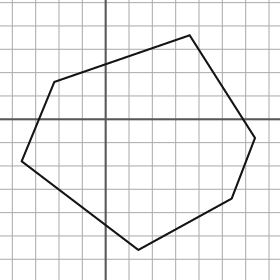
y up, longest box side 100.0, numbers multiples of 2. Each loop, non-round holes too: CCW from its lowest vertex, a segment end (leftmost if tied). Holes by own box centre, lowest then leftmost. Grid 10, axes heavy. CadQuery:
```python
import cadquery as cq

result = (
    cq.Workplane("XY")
    .moveTo(14.0, -56.0)
    .lineTo(54.0, -34.0)
    .lineTo(64.0, -8.0)
    .lineTo(36.0, 36.0)
    .lineTo(-22.0, 16.0)
    .lineTo(-36.0, -18.0)
    .close()
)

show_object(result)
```